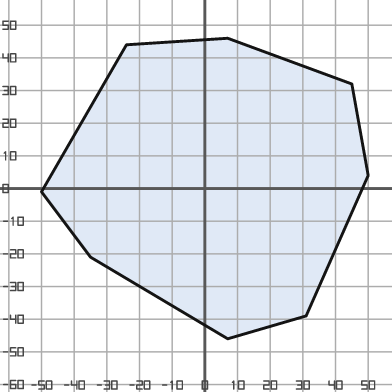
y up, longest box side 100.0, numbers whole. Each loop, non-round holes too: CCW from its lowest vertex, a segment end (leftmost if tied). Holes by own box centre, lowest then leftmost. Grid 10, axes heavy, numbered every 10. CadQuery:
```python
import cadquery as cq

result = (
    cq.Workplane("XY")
    .moveTo(7.0, -46.0)
    .lineTo(31.0, -39.0)
    .lineTo(50.0, 4.0)
    .lineTo(45.0, 32.0)
    .lineTo(7.0, 46.0)
    .lineTo(-24.0, 44.0)
    .lineTo(-50.0, -1.0)
    .lineTo(-35.0, -21.0)
    .close()
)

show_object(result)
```